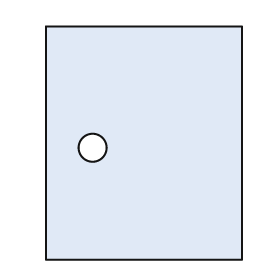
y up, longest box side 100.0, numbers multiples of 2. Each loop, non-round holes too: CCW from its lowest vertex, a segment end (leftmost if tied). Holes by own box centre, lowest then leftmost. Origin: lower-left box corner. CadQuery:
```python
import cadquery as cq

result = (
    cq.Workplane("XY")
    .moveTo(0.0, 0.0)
    .lineTo(84.0, 0.0)
    .lineTo(84.0, 100.0)
    .lineTo(0.0, 100.0)
    .close()
    .moveTo(20.0, 48.0)
    .circle(6.0)
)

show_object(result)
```